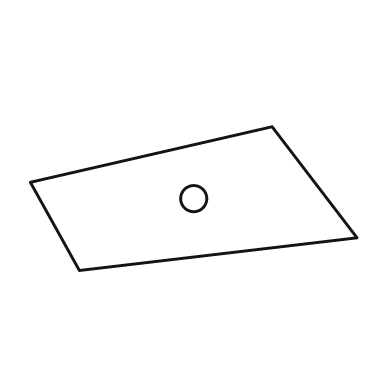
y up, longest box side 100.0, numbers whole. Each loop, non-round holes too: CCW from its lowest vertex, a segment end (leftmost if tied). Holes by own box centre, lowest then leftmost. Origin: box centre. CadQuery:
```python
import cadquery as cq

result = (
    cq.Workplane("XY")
    .moveTo(-35.0, -22.0)
    .lineTo(50.0, -12.0)
    .lineTo(24.0, 22.0)
    .lineTo(-50.0, 5.0)
    .close()
    .moveTo(0.0, 0.0)
    .circle(4.0)
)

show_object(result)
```